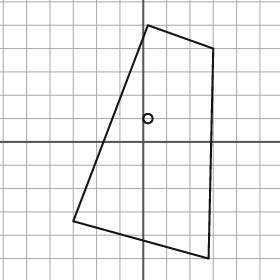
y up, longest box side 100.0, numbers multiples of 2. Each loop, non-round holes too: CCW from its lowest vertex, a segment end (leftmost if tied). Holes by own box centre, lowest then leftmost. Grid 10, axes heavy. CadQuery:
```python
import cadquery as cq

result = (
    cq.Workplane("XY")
    .moveTo(28.0, -50.0)
    .lineTo(30.0, 40.0)
    .lineTo(2.0, 50.0)
    .lineTo(-30.0, -34.0)
    .close()
    .moveTo(2.0, 10.0)
    .circle(2.0)
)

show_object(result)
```